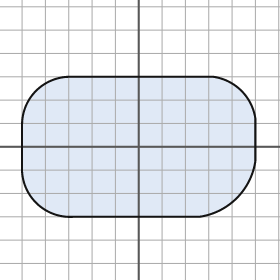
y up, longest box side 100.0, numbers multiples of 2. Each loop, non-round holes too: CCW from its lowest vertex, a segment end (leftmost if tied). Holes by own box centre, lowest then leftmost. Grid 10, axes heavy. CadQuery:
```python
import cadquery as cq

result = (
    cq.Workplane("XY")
    .moveTo(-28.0, -30.0)
    .lineTo(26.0, -30.0)
    .threePointArc((42.0, -22.0), (50.0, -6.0))
    .lineTo(50.0, 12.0)
    .threePointArc((44.0, 24.0), (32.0, 30.0))
    .lineTo(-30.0, 30.0)
    .threePointArc((-44.0, 24.0), (-50.0, 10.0))
    .lineTo(-50.0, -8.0)
    .threePointArc((-44.0, -24.0), (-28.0, -30.0))
    .close()
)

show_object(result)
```